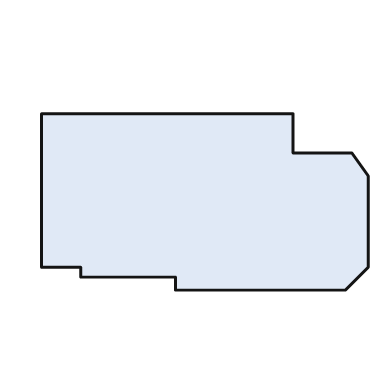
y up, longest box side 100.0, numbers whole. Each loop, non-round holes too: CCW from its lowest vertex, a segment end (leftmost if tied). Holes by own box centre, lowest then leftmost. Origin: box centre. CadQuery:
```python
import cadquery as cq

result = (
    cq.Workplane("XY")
    .moveTo(-9.0, -27.0)
    .lineTo(43.0, -27.0)
    .lineTo(50.0, -20.0)
    .lineTo(50.0, 8.0)
    .lineTo(45.0, 15.0)
    .lineTo(27.0, 15.0)
    .lineTo(27.0, 27.0)
    .lineTo(-50.0, 27.0)
    .lineTo(-50.0, -20.0)
    .lineTo(-38.0, -20.0)
    .lineTo(-38.0, -23.0)
    .lineTo(-9.0, -23.0)
    .close()
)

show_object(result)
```